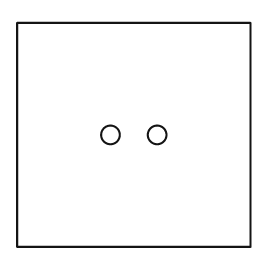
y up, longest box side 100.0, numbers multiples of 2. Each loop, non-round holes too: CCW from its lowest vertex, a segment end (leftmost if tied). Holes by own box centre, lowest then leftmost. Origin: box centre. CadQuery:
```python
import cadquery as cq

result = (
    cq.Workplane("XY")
    .moveTo(-50.0, -48.0)
    .lineTo(50.0, -48.0)
    .lineTo(50.0, 48.0)
    .lineTo(-50.0, 48.0)
    .close()
    .moveTo(-10.0, 0.0)
    .circle(4.0)
    .moveTo(10.0, 0.0)
    .circle(4.0)
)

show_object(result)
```